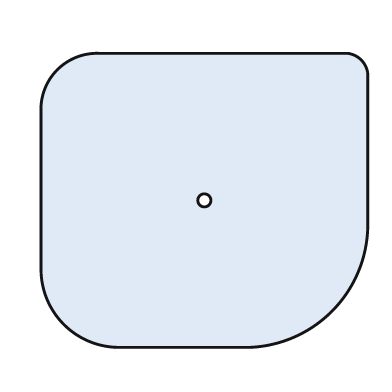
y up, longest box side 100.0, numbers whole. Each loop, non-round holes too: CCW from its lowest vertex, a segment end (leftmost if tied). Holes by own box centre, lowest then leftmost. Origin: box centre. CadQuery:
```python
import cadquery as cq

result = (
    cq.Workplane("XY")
    .moveTo(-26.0, -45.0)
    .lineTo(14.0, -45.0)
    .threePointArc((39.0, -34.0), (50.0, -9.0))
    .lineTo(50.0, 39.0)
    .threePointArc((48.0, 43.0), (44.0, 45.0))
    .lineTo(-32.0, 45.0)
    .threePointArc((-45.0, 40.0), (-50.0, 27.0))
    .lineTo(-50.0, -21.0)
    .threePointArc((-43.0, -38.0), (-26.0, -45.0))
    .close()
    .moveTo(0.0, 0.0)
    .circle(2.0)
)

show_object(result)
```